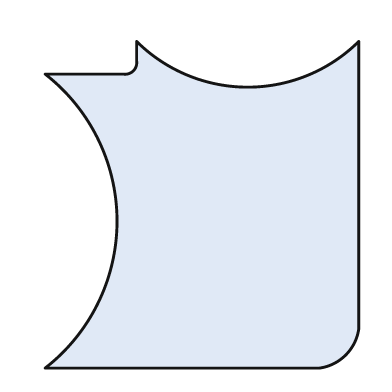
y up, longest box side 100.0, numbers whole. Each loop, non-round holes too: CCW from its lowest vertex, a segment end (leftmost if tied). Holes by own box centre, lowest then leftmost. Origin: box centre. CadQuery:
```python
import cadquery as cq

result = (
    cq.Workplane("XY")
    .moveTo(-48.0, -50.0)
    .lineTo(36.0, -50.0)
    .threePointArc((44.0, -46.0), (48.0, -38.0))
    .lineTo(48.0, 50.0)
    .threePointArc((14.0, 36.0), (-20.0, 50.0))
    .lineTo(-20.0, 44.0)
    .threePointArc((-21.0, 41.0), (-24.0, 40.0))
    .lineTo(-48.0, 40.0)
    .threePointArc((-26.0, -5.0), (-48.0, -50.0))
    .close()
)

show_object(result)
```